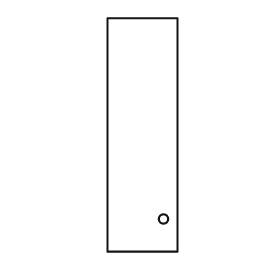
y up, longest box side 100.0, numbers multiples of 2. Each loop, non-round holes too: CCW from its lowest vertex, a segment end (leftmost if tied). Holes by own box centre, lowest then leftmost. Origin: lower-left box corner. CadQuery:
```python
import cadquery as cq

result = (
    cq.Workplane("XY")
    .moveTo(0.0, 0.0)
    .lineTo(30.0, 0.0)
    .lineTo(30.0, 100.0)
    .lineTo(0.0, 100.0)
    .close()
    .moveTo(24.0, 14.0)
    .circle(2.0)
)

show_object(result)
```